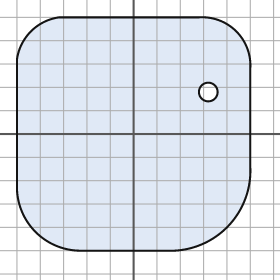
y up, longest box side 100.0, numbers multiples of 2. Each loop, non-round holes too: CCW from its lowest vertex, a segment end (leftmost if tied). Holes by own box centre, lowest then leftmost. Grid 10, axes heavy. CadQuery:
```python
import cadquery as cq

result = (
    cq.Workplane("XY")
    .moveTo(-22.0, -50.0)
    .lineTo(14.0, -50.0)
    .threePointArc((40.0, -40.0), (50.0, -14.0))
    .lineTo(50.0, 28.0)
    .threePointArc((44.0, 44.0), (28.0, 50.0))
    .lineTo(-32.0, 50.0)
    .threePointArc((-44.0, 44.0), (-50.0, 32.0))
    .lineTo(-50.0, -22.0)
    .threePointArc((-42.0, -42.0), (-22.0, -50.0))
    .close()
    .moveTo(32.0, 18.0)
    .circle(4.0)
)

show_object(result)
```